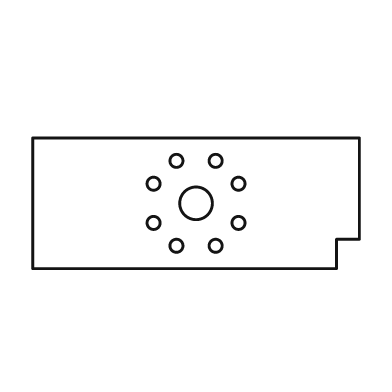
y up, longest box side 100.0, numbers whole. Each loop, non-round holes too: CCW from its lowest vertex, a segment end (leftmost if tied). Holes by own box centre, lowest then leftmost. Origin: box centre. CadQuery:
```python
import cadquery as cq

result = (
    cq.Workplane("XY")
    .moveTo(-50.0, -20.0)
    .lineTo(43.0, -20.0)
    .lineTo(43.0, -11.0)
    .lineTo(50.0, -11.0)
    .lineTo(50.0, 20.0)
    .lineTo(-50.0, 20.0)
    .close()
    .moveTo(-6.0, -13.0)
    .circle(2.0)
    .moveTo(6.0, -13.0)
    .circle(2.0)
    .moveTo(-13.0, -6.0)
    .circle(2.0)
    .moveTo(13.0, -6.0)
    .circle(2.0)
    .moveTo(0.0, 0.0)
    .circle(5.0)
    .moveTo(-13.0, 6.0)
    .circle(2.0)
    .moveTo(13.0, 6.0)
    .circle(2.0)
    .moveTo(-6.0, 13.0)
    .circle(2.0)
    .moveTo(6.0, 13.0)
    .circle(2.0)
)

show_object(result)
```